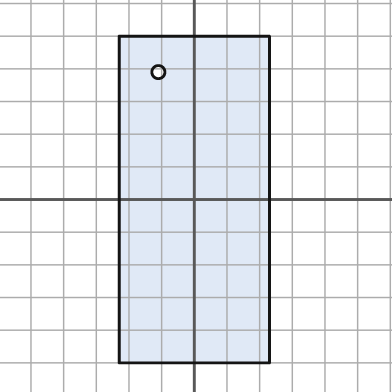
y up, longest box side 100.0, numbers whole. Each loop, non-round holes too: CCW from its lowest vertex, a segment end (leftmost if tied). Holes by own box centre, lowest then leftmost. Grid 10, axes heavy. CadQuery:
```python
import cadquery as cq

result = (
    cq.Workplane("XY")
    .moveTo(-23.0, -50.0)
    .lineTo(23.0, -50.0)
    .lineTo(23.0, 50.0)
    .lineTo(-23.0, 50.0)
    .close()
    .moveTo(-11.0, 39.0)
    .circle(2.0)
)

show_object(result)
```